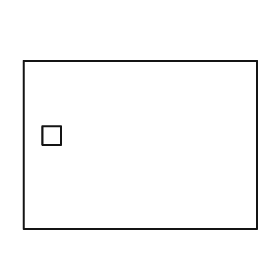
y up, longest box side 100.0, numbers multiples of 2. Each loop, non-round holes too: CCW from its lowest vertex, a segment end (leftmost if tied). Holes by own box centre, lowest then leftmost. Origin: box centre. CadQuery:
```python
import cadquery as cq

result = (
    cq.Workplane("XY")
    .moveTo(-50.0, -36.0)
    .lineTo(50.0, -36.0)
    .lineTo(50.0, 36.0)
    .lineTo(-50.0, 36.0)
    .close()
    .moveTo(-42.0, 0.0)
    .lineTo(-34.0, 0.0)
    .lineTo(-34.0, 8.0)
    .lineTo(-42.0, 8.0)
    .close()
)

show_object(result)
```